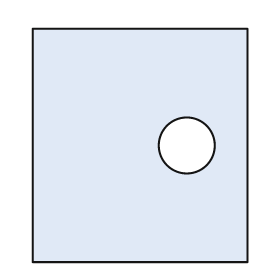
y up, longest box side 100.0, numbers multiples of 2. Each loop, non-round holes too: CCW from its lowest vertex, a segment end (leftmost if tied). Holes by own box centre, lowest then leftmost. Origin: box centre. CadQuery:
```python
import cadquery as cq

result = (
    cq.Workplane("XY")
    .moveTo(-46.0, -50.0)
    .lineTo(46.0, -50.0)
    .lineTo(46.0, 50.0)
    .lineTo(-46.0, 50.0)
    .close()
    .moveTo(20.0, 0.0)
    .circle(12.0)
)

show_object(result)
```